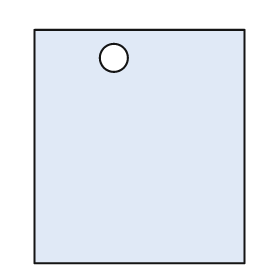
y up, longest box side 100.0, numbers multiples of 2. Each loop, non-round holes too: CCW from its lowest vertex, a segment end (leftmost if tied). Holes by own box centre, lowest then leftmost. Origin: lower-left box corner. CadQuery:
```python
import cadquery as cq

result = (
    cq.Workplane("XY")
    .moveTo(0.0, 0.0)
    .lineTo(90.0, 0.0)
    .lineTo(90.0, 100.0)
    .lineTo(0.0, 100.0)
    .close()
    .moveTo(34.0, 88.0)
    .circle(6.0)
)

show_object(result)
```